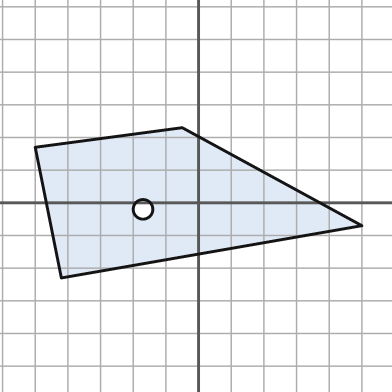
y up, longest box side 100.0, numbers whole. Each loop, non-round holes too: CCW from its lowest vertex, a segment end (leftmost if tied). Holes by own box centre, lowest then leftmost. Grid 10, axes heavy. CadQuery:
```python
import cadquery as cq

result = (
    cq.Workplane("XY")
    .moveTo(-42.0, -23.0)
    .lineTo(50.0, -7.0)
    .lineTo(-5.0, 23.0)
    .lineTo(-50.0, 17.0)
    .close()
    .moveTo(-17.0, -2.0)
    .circle(3.0)
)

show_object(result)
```